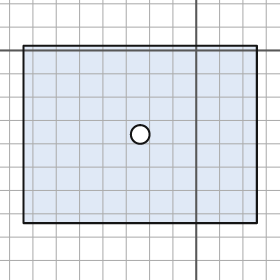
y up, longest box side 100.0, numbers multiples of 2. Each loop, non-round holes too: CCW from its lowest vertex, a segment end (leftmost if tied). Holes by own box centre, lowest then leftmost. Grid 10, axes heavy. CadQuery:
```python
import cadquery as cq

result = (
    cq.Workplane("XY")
    .moveTo(-74.0, -74.0)
    .lineTo(26.0, -74.0)
    .lineTo(26.0, 2.0)
    .lineTo(-74.0, 2.0)
    .close()
    .moveTo(-24.0, -36.0)
    .circle(4.0)
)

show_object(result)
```